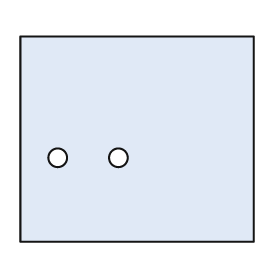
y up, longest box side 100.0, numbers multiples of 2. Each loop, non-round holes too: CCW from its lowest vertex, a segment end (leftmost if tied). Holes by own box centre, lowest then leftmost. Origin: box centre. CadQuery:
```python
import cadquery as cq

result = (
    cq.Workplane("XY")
    .moveTo(-50.0, -44.0)
    .lineTo(50.0, -44.0)
    .lineTo(50.0, 44.0)
    .lineTo(-50.0, 44.0)
    .close()
    .moveTo(-34.0, -8.0)
    .circle(4.0)
    .moveTo(-8.0, -8.0)
    .circle(4.0)
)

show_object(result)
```